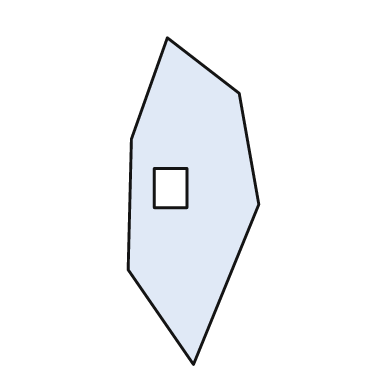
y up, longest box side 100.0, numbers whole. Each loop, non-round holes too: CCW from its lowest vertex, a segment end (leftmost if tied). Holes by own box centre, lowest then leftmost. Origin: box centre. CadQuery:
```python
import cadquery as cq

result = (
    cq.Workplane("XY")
    .moveTo(0.0, -50.0)
    .lineTo(20.0, -1.0)
    .lineTo(14.0, 33.0)
    .lineTo(-8.0, 50.0)
    .lineTo(-19.0, 19.0)
    .lineTo(-20.0, -21.0)
    .close()
    .moveTo(-12.0, -2.0)
    .lineTo(-2.0, -2.0)
    .lineTo(-2.0, 10.0)
    .lineTo(-12.0, 10.0)
    .close()
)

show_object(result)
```